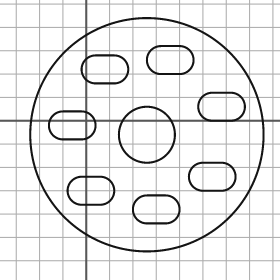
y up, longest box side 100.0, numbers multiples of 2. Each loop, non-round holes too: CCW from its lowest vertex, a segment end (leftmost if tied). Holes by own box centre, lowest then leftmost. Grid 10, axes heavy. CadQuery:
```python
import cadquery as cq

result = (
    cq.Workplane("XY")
    .moveTo(26.0, -6.0)
    .circle(50.0)
    .moveTo(26.0, -44.0)
    .lineTo(34.0, -44.0)
    .threePointArc((40.0, -38.0), (34.0, -32.0))
    .lineTo(26.0, -32.0)
    .threePointArc((20.0, -38.0), (26.0, -44.0))
    .close()
    .moveTo(-2.0, -36.0)
    .lineTo(6.0, -36.0)
    .threePointArc((12.0, -30.0), (6.0, -24.0))
    .lineTo(-2.0, -24.0)
    .threePointArc((-8.0, -30.0), (-2.0, -36.0))
    .close()
    .moveTo(50.0, -30.0)
    .lineTo(58.0, -30.0)
    .threePointArc((64.0, -24.0), (58.0, -18.0))
    .lineTo(50.0, -18.0)
    .threePointArc((44.0, -24.0), (50.0, -30.0))
    .close()
    .moveTo(26.0, -6.0)
    .circle(12.0)
    .moveTo(-10.0, -8.0)
    .lineTo(-2.0, -8.0)
    .threePointArc((4.0, -2.0), (-2.0, 4.0))
    .lineTo(-10.0, 4.0)
    .threePointArc((-16.0, -2.0), (-10.0, -8.0))
    .close()
    .moveTo(54.0, 0.0)
    .lineTo(62.0, 0.0)
    .threePointArc((68.0, 6.0), (62.0, 12.0))
    .lineTo(54.0, 12.0)
    .threePointArc((48.0, 6.0), (54.0, 0.0))
    .close()
    .moveTo(4.0, 16.0)
    .lineTo(12.0, 16.0)
    .threePointArc((18.0, 22.0), (12.0, 28.0))
    .lineTo(4.0, 28.0)
    .threePointArc((-2.0, 22.0), (4.0, 16.0))
    .close()
    .moveTo(32.0, 20.0)
    .lineTo(40.0, 20.0)
    .threePointArc((46.0, 26.0), (40.0, 32.0))
    .lineTo(32.0, 32.0)
    .threePointArc((26.0, 26.0), (32.0, 20.0))
    .close()
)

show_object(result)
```